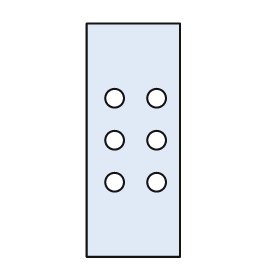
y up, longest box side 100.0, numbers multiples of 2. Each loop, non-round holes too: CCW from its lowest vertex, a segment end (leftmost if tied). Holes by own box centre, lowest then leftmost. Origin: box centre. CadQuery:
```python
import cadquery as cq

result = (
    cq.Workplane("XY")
    .moveTo(-20.0, -50.0)
    .lineTo(20.0, -50.0)
    .lineTo(20.0, 50.0)
    .lineTo(-20.0, 50.0)
    .close()
    .moveTo(-8.0, -18.0)
    .circle(4.0)
    .moveTo(10.0, -18.0)
    .circle(4.0)
    .moveTo(-8.0, 0.0)
    .circle(4.0)
    .moveTo(10.0, 0.0)
    .circle(4.0)
    .moveTo(-8.0, 18.0)
    .circle(4.0)
    .moveTo(10.0, 18.0)
    .circle(4.0)
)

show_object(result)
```